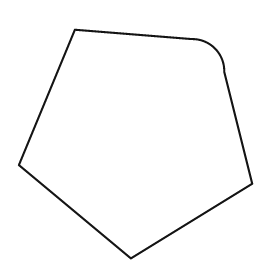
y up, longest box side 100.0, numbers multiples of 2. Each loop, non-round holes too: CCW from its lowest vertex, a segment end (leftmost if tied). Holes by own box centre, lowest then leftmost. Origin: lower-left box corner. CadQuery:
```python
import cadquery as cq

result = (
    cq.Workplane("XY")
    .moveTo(48.0, 0.0)
    .lineTo(100.0, 32.0)
    .lineTo(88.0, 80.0)
    .threePointArc((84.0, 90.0), (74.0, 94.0))
    .lineTo(24.0, 98.0)
    .lineTo(0.0, 40.0)
    .close()
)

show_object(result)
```